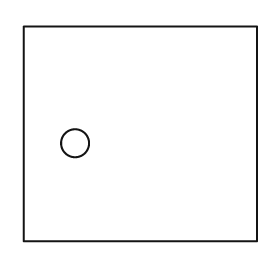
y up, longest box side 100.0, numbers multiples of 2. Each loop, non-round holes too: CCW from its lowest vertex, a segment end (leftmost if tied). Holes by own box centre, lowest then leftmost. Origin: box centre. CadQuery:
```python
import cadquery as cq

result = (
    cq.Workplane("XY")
    .moveTo(-50.0, -46.0)
    .lineTo(50.0, -46.0)
    .lineTo(50.0, 46.0)
    .lineTo(-50.0, 46.0)
    .close()
    .moveTo(-28.0, -4.0)
    .circle(6.0)
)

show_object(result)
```